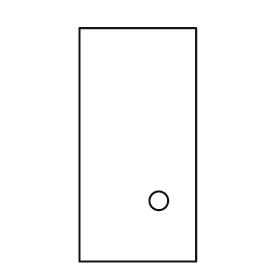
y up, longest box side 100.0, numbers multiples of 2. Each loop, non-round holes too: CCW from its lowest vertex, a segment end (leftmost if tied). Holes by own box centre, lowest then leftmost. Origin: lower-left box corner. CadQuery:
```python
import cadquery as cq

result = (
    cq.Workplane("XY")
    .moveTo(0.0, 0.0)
    .lineTo(50.0, 0.0)
    .lineTo(50.0, 100.0)
    .lineTo(0.0, 100.0)
    .close()
    .moveTo(34.0, 26.0)
    .circle(4.0)
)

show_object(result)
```